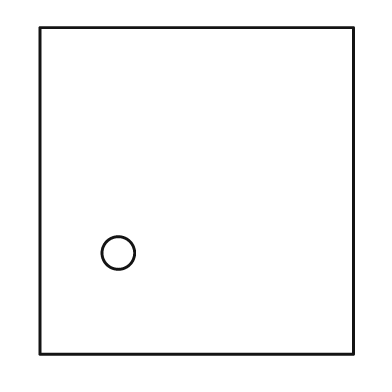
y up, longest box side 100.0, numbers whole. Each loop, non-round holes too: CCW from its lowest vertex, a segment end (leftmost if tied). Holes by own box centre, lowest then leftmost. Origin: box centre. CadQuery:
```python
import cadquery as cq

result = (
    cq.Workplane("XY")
    .moveTo(-48.0, -50.0)
    .lineTo(48.0, -50.0)
    .lineTo(48.0, 50.0)
    .lineTo(-48.0, 50.0)
    .close()
    .moveTo(-24.0, -19.0)
    .circle(5.0)
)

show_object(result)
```